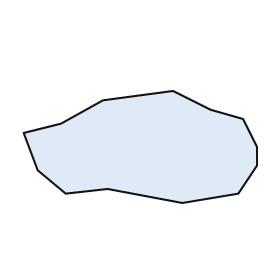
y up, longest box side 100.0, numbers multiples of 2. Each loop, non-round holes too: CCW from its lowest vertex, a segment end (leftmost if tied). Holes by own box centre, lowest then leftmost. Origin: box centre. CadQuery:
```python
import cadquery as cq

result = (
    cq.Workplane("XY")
    .moveTo(18.0, -24.0)
    .lineTo(42.0, -20.0)
    .lineTo(50.0, -8.0)
    .lineTo(50.0, 0.0)
    .lineTo(44.0, 12.0)
    .lineTo(30.0, 16.0)
    .lineTo(14.0, 24.0)
    .lineTo(-16.0, 20.0)
    .lineTo(-34.0, 10.0)
    .lineTo(-50.0, 6.0)
    .lineTo(-44.0, -10.0)
    .lineTo(-32.0, -20.0)
    .lineTo(-14.0, -18.0)
    .close()
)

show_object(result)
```